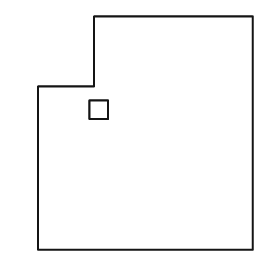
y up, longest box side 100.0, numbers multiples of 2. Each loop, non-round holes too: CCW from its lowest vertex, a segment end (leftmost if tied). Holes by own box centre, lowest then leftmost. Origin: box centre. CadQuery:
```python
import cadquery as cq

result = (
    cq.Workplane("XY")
    .moveTo(-46.0, -50.0)
    .lineTo(46.0, -50.0)
    .lineTo(46.0, 50.0)
    .lineTo(-22.0, 50.0)
    .lineTo(-22.0, 20.0)
    .lineTo(-46.0, 20.0)
    .close()
    .moveTo(-24.0, 6.0)
    .lineTo(-16.0, 6.0)
    .lineTo(-16.0, 14.0)
    .lineTo(-24.0, 14.0)
    .close()
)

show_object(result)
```